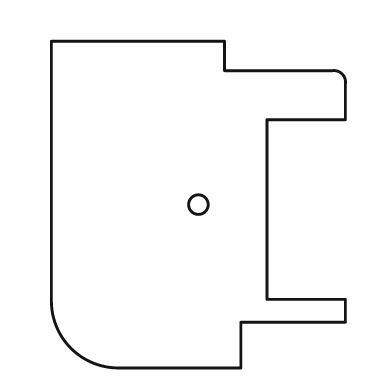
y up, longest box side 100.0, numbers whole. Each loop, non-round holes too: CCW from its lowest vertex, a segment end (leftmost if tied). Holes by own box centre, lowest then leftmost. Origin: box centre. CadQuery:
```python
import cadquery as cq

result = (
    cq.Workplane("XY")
    .moveTo(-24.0, -50.0)
    .lineTo(13.0, -50.0)
    .lineTo(13.0, -36.0)
    .lineTo(45.0, -36.0)
    .lineTo(45.0, -29.0)
    .lineTo(21.0, -29.0)
    .lineTo(21.0, 26.0)
    .lineTo(45.0, 26.0)
    .lineTo(45.0, 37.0)
    .threePointArc((44.0, 40.0), (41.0, 41.0))
    .lineTo(8.0, 41.0)
    .lineTo(8.0, 50.0)
    .lineTo(-45.0, 50.0)
    .lineTo(-45.0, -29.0)
    .threePointArc((-39.0, -44.0), (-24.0, -50.0))
    .close()
    .moveTo(0.0, 0.0)
    .circle(3.0)
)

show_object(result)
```